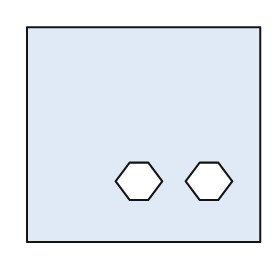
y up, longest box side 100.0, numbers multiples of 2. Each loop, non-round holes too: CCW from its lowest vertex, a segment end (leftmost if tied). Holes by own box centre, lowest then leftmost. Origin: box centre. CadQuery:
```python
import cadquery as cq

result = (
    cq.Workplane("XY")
    .moveTo(-50.0, -46.0)
    .lineTo(50.0, -46.0)
    .lineTo(50.0, 46.0)
    .lineTo(-50.0, 46.0)
    .close()
    .moveTo(-6.0, -28.0)
    .lineTo(2.0, -28.0)
    .lineTo(8.0, -20.0)
    .lineTo(2.0, -12.0)
    .lineTo(-6.0, -12.0)
    .lineTo(-12.0, -20.0)
    .close()
    .moveTo(24.0, -28.0)
    .lineTo(32.0, -28.0)
    .lineTo(38.0, -20.0)
    .lineTo(32.0, -12.0)
    .lineTo(24.0, -12.0)
    .lineTo(18.0, -20.0)
    .close()
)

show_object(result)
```